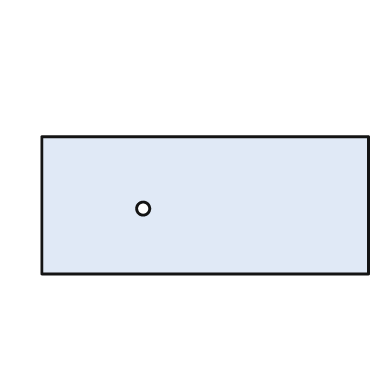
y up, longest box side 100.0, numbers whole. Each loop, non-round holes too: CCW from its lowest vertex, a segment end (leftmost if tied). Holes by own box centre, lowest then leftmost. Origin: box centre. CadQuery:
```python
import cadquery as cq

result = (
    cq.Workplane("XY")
    .moveTo(-50.0, -21.0)
    .lineTo(50.0, -21.0)
    .lineTo(50.0, 21.0)
    .lineTo(-50.0, 21.0)
    .close()
    .moveTo(-19.0, -1.0)
    .circle(2.0)
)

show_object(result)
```